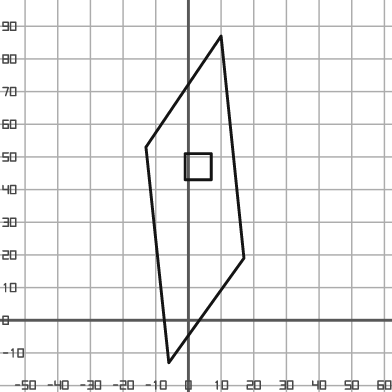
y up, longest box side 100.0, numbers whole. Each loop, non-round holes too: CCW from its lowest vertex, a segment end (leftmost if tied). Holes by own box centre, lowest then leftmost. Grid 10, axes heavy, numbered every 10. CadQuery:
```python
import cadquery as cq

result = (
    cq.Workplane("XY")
    .moveTo(-6.0, -13.0)
    .lineTo(17.0, 19.0)
    .lineTo(10.0, 87.0)
    .lineTo(-13.0, 53.0)
    .close()
    .moveTo(-1.0, 43.0)
    .lineTo(7.0, 43.0)
    .lineTo(7.0, 51.0)
    .lineTo(-1.0, 51.0)
    .close()
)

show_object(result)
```